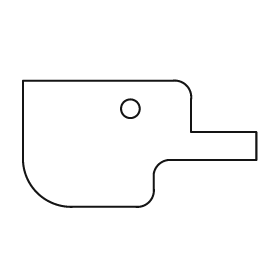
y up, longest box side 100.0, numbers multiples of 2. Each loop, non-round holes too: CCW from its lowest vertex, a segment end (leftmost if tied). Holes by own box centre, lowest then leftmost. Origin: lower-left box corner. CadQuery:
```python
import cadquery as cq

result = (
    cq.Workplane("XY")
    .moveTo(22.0, 0.0)
    .lineTo(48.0, 0.0)
    .threePointArc((54.0, 2.0), (56.0, 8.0))
    .lineTo(56.0, 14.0)
    .threePointArc((58.0, 18.0), (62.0, 20.0))
    .lineTo(100.0, 20.0)
    .lineTo(100.0, 32.0)
    .lineTo(72.0, 32.0)
    .lineTo(72.0, 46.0)
    .threePointArc((70.0, 52.0), (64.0, 54.0))
    .lineTo(0.0, 54.0)
    .lineTo(0.0, 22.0)
    .threePointArc((6.0, 6.0), (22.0, 0.0))
    .close()
    .moveTo(46.0, 42.0)
    .circle(4.0)
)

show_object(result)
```